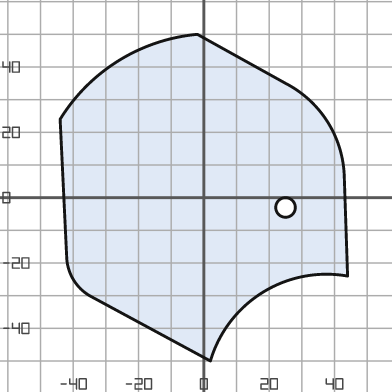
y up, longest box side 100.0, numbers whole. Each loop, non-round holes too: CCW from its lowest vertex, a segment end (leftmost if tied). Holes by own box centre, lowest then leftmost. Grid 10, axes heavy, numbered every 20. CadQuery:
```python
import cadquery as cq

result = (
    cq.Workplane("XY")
    .moveTo(2.0, -50.0)
    .threePointArc((18.0, -29.0), (44.0, -24.0))
    .lineTo(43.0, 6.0)
    .threePointArc((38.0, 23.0), (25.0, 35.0))
    .lineTo(-2.0, 50.0)
    .threePointArc((-26.0, 42.0), (-44.0, 24.0))
    .lineTo(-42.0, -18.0)
    .threePointArc((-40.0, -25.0), (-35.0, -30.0))
    .close()
    .moveTo(25.0, -3.0)
    .circle(3.0)
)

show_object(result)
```